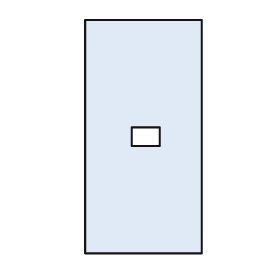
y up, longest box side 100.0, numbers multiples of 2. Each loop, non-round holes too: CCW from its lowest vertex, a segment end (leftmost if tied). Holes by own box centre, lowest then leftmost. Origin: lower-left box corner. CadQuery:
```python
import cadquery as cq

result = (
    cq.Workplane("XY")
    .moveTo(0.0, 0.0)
    .lineTo(50.0, 0.0)
    .lineTo(50.0, 100.0)
    .lineTo(0.0, 100.0)
    .close()
    .moveTo(20.0, 46.0)
    .lineTo(32.0, 46.0)
    .lineTo(32.0, 54.0)
    .lineTo(20.0, 54.0)
    .close()
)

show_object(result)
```